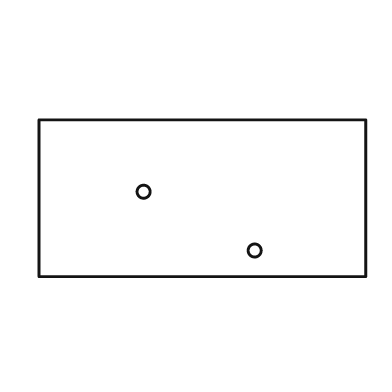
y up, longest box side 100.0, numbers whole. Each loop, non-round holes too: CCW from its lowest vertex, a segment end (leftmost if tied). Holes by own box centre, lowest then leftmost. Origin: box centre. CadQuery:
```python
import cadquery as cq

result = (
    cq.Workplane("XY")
    .moveTo(-50.0, -24.0)
    .lineTo(50.0, -24.0)
    .lineTo(50.0, 24.0)
    .lineTo(-50.0, 24.0)
    .close()
    .moveTo(16.0, -16.0)
    .circle(2.0)
    .moveTo(-18.0, 2.0)
    .circle(2.0)
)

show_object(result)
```